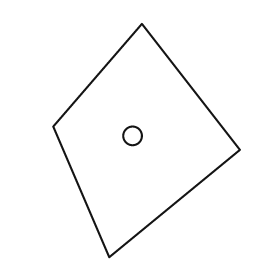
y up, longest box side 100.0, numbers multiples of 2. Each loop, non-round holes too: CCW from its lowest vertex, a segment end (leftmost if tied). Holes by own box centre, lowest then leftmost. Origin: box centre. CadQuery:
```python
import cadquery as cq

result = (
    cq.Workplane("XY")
    .moveTo(-16.0, -50.0)
    .lineTo(40.0, -4.0)
    .lineTo(-2.0, 50.0)
    .lineTo(-40.0, 6.0)
    .close()
    .moveTo(-6.0, 2.0)
    .circle(4.0)
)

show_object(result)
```